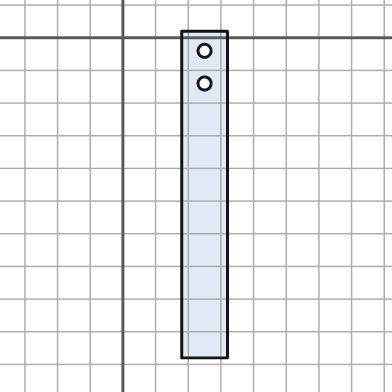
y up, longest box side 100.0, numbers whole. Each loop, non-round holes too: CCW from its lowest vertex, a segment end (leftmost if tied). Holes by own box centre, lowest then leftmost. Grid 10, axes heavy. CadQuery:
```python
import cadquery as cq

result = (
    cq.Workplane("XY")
    .moveTo(18.0, -98.0)
    .lineTo(32.0, -98.0)
    .lineTo(32.0, 2.0)
    .lineTo(18.0, 2.0)
    .close()
    .moveTo(25.0, -14.0)
    .circle(2.0)
    .moveTo(25.0, -4.0)
    .circle(2.0)
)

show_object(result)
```